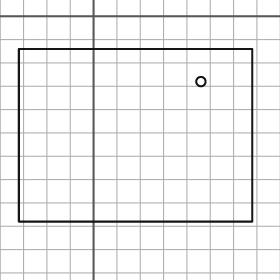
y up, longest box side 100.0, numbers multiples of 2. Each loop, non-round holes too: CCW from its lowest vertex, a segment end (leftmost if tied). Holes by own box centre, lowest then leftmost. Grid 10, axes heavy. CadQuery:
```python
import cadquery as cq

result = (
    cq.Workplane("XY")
    .moveTo(-32.0, -88.0)
    .lineTo(68.0, -88.0)
    .lineTo(68.0, -14.0)
    .lineTo(-32.0, -14.0)
    .close()
    .moveTo(46.0, -28.0)
    .circle(2.0)
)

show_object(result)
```